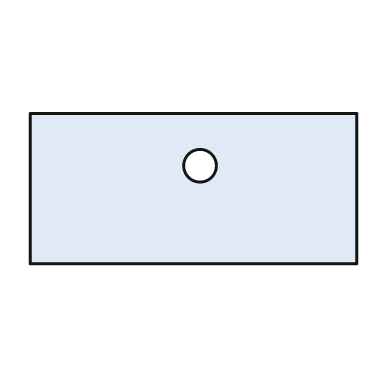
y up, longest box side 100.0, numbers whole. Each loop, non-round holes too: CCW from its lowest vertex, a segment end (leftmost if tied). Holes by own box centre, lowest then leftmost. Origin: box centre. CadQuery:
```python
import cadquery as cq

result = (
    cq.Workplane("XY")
    .moveTo(-50.0, -23.0)
    .lineTo(50.0, -23.0)
    .lineTo(50.0, 23.0)
    .lineTo(-50.0, 23.0)
    .close()
    .moveTo(2.0, 7.0)
    .circle(5.0)
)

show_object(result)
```